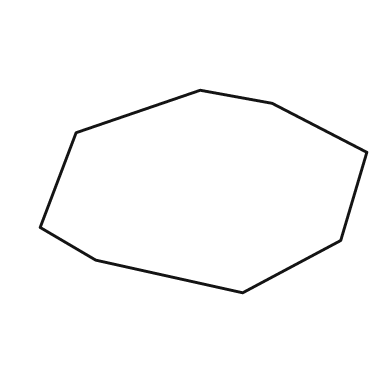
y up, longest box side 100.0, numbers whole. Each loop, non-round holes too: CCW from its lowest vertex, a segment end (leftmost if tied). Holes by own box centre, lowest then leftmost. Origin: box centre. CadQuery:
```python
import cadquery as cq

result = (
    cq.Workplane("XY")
    .moveTo(12.0, -31.0)
    .lineTo(42.0, -15.0)
    .lineTo(50.0, 12.0)
    .lineTo(21.0, 27.0)
    .lineTo(-1.0, 31.0)
    .lineTo(-39.0, 18.0)
    .lineTo(-50.0, -11.0)
    .lineTo(-33.0, -21.0)
    .close()
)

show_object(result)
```